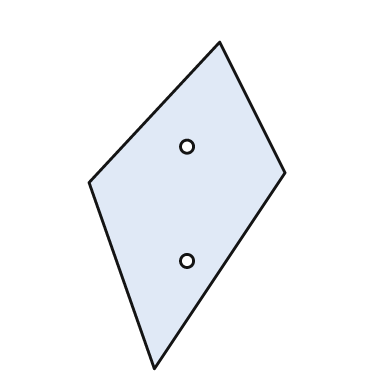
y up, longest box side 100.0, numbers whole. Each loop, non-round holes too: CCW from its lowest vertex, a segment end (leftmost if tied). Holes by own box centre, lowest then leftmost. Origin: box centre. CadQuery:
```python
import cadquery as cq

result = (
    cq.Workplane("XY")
    .moveTo(-10.0, -50.0)
    .lineTo(30.0, 10.0)
    .lineTo(10.0, 50.0)
    .lineTo(-30.0, 7.0)
    .close()
    .moveTo(0.0, -17.0)
    .circle(2.0)
    .moveTo(0.0, 18.0)
    .circle(2.0)
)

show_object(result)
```